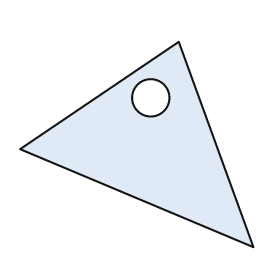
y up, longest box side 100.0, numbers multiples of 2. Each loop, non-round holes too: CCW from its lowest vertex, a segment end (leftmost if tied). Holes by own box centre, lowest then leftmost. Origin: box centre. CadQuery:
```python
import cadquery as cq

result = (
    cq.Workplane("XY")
    .moveTo(50.0, -44.0)
    .lineTo(18.0, 44.0)
    .lineTo(-50.0, -2.0)
    .close()
    .moveTo(6.0, 20.0)
    .circle(8.0)
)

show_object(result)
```